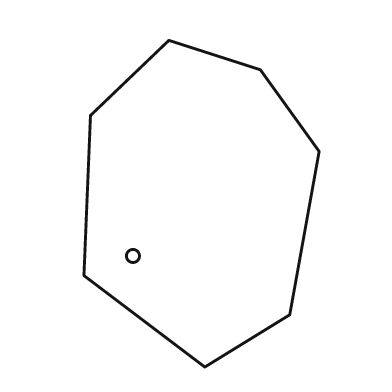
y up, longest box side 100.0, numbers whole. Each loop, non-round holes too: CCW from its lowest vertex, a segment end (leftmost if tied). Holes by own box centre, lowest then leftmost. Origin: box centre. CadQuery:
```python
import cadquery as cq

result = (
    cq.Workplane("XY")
    .moveTo(1.0, -50.0)
    .lineTo(27.0, -34.0)
    .lineTo(36.0, 16.0)
    .lineTo(18.0, 41.0)
    .lineTo(-10.0, 50.0)
    .lineTo(-34.0, 27.0)
    .lineTo(-36.0, -22.0)
    .close()
    .moveTo(-21.0, -16.0)
    .circle(2.0)
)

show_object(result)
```